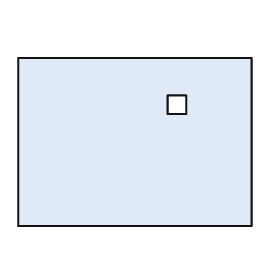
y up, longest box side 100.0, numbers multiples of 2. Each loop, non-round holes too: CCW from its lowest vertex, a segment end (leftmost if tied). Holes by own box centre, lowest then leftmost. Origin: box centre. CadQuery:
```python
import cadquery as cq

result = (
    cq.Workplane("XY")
    .moveTo(-50.0, -36.0)
    .lineTo(50.0, -36.0)
    .lineTo(50.0, 36.0)
    .lineTo(-50.0, 36.0)
    .close()
    .moveTo(14.0, 12.0)
    .lineTo(22.0, 12.0)
    .lineTo(22.0, 20.0)
    .lineTo(14.0, 20.0)
    .close()
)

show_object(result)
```